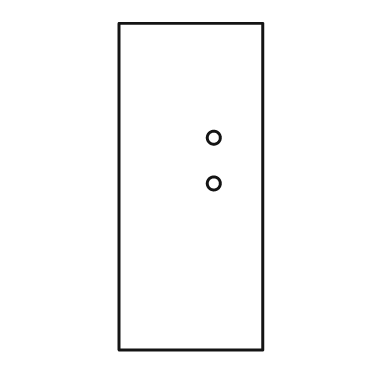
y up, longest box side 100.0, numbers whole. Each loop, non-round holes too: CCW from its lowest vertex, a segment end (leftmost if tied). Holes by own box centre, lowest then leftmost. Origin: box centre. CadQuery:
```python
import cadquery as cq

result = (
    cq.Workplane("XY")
    .moveTo(-22.0, -50.0)
    .lineTo(22.0, -50.0)
    .lineTo(22.0, 50.0)
    .lineTo(-22.0, 50.0)
    .close()
    .moveTo(7.0, 1.0)
    .circle(2.0)
    .moveTo(7.0, 15.0)
    .circle(2.0)
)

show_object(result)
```